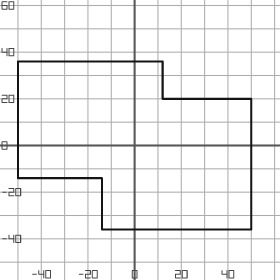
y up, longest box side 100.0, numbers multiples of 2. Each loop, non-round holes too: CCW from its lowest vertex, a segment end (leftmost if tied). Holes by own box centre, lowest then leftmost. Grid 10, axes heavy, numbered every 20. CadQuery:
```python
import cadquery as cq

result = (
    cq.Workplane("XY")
    .moveTo(-14.0, -36.0)
    .lineTo(50.0, -36.0)
    .lineTo(50.0, 20.0)
    .lineTo(12.0, 20.0)
    .lineTo(12.0, 36.0)
    .lineTo(-50.0, 36.0)
    .lineTo(-50.0, -14.0)
    .lineTo(-14.0, -14.0)
    .close()
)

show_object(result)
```